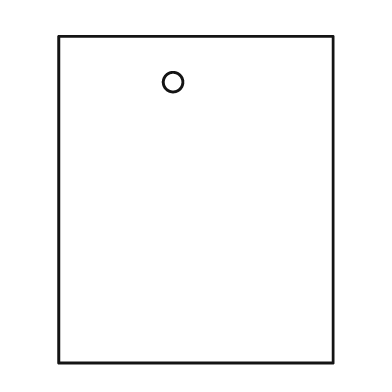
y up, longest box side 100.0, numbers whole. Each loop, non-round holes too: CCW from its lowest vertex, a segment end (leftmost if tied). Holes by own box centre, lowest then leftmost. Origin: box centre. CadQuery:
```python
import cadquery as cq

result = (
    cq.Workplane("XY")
    .moveTo(-42.0, -50.0)
    .lineTo(42.0, -50.0)
    .lineTo(42.0, 50.0)
    .lineTo(-42.0, 50.0)
    .close()
    .moveTo(-7.0, 36.0)
    .circle(3.0)
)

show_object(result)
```